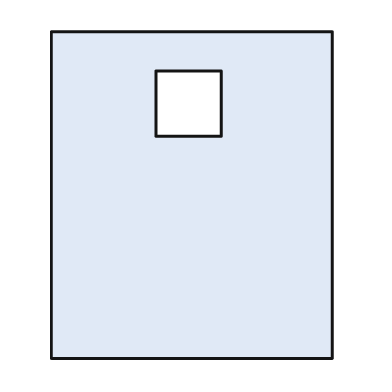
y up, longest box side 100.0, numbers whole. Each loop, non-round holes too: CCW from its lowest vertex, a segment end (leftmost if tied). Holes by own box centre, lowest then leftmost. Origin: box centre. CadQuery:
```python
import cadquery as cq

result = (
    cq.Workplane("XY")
    .moveTo(-43.0, -50.0)
    .lineTo(43.0, -50.0)
    .lineTo(43.0, 50.0)
    .lineTo(-43.0, 50.0)
    .close()
    .moveTo(-11.0, 18.0)
    .lineTo(9.0, 18.0)
    .lineTo(9.0, 38.0)
    .lineTo(-11.0, 38.0)
    .close()
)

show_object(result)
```